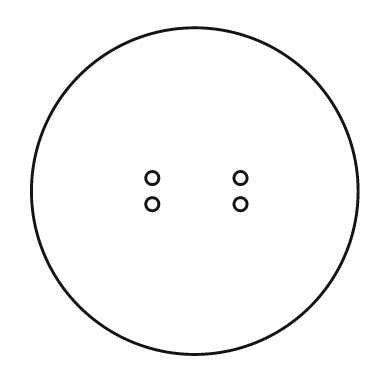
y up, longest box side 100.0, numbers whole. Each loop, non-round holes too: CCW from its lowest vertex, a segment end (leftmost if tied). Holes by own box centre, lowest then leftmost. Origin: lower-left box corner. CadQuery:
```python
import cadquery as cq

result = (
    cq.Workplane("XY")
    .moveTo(50.0, 50.0)
    .circle(50.0)
    .moveTo(37.0, 46.0)
    .circle(2.0)
    .moveTo(64.0, 46.0)
    .circle(2.0)
    .moveTo(37.0, 54.0)
    .circle(2.0)
    .moveTo(64.0, 54.0)
    .circle(2.0)
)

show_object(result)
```